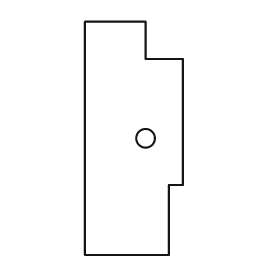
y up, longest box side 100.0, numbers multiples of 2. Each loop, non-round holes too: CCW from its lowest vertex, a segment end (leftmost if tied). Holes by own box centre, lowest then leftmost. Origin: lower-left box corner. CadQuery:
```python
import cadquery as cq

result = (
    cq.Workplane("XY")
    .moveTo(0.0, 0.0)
    .lineTo(36.0, 0.0)
    .lineTo(36.0, 30.0)
    .lineTo(42.0, 30.0)
    .lineTo(42.0, 84.0)
    .lineTo(26.0, 84.0)
    .lineTo(26.0, 100.0)
    .lineTo(0.0, 100.0)
    .close()
    .moveTo(26.0, 50.0)
    .circle(4.0)
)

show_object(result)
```